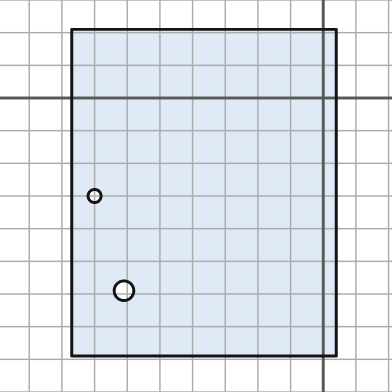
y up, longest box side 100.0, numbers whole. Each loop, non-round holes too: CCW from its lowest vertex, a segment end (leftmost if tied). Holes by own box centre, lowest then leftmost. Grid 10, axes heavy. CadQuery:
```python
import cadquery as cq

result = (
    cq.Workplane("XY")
    .moveTo(-77.0, -79.0)
    .lineTo(4.0, -79.0)
    .lineTo(4.0, 21.0)
    .lineTo(-77.0, 21.0)
    .close()
    .moveTo(-61.0, -59.0)
    .circle(3.0)
    .moveTo(-70.0, -30.0)
    .circle(2.0)
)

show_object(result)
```